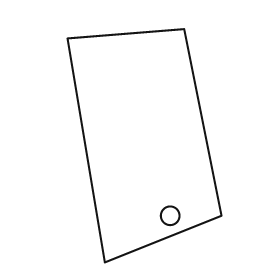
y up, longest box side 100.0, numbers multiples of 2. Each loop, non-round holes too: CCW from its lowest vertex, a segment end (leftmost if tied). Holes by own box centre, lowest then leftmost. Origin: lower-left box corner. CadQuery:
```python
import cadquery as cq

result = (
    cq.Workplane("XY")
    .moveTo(16.0, 0.0)
    .lineTo(66.0, 20.0)
    .lineTo(50.0, 100.0)
    .lineTo(0.0, 96.0)
    .close()
    .moveTo(44.0, 20.0)
    .circle(4.0)
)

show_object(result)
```